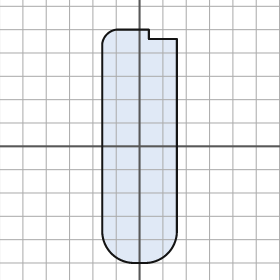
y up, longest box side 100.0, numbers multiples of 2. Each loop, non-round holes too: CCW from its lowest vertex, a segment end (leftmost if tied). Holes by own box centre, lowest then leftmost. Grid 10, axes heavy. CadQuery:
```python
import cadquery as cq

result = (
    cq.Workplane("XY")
    .moveTo(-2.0, -50.0)
    .lineTo(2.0, -50.0)
    .threePointArc((12.0, -46.0), (16.0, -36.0))
    .lineTo(16.0, 46.0)
    .lineTo(4.0, 46.0)
    .lineTo(4.0, 50.0)
    .lineTo(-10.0, 50.0)
    .threePointArc((-14.0, 48.0), (-16.0, 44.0))
    .lineTo(-16.0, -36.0)
    .threePointArc((-12.0, -46.0), (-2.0, -50.0))
    .close()
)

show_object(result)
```